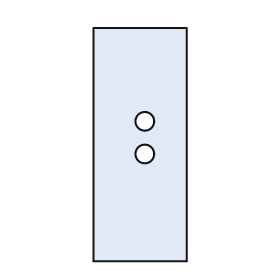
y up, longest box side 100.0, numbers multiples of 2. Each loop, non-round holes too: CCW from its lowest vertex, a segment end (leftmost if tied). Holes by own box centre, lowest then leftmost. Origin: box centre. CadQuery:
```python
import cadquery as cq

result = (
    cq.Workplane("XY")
    .moveTo(-20.0, -50.0)
    .lineTo(20.0, -50.0)
    .lineTo(20.0, 50.0)
    .lineTo(-20.0, 50.0)
    .close()
    .moveTo(2.0, -4.0)
    .circle(4.0)
    .moveTo(2.0, 10.0)
    .circle(4.0)
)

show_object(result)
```